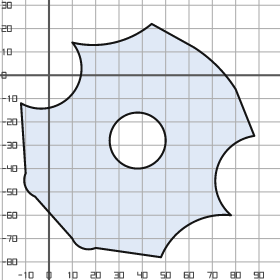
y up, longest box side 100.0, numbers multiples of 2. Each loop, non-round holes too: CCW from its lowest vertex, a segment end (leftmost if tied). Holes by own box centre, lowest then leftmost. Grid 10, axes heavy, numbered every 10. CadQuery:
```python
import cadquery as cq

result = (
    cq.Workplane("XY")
    .moveTo(48.0, -78.0)
    .threePointArc((60.0, -64.0), (78.0, -60.0))
    .threePointArc((72.0, -40.0), (88.0, -26.0))
    .lineTo(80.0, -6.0)
    .threePointArc((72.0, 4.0), (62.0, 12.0))
    .lineTo(44.0, 22.0)
    .threePointArc((28.0, 14.0), (10.0, 14.0))
    .threePointArc((10.0, -8.0), (-12.0, -12.0))
    .lineTo(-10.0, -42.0)
    .threePointArc((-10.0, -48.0), (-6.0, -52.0))
    .lineTo(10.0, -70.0)
    .threePointArc((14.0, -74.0), (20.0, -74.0))
    .close()
    .moveTo(38.0, -28.0)
    .circle(12.0)
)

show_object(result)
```